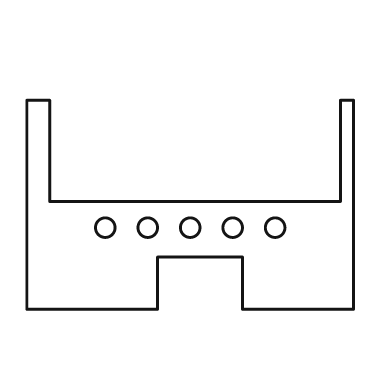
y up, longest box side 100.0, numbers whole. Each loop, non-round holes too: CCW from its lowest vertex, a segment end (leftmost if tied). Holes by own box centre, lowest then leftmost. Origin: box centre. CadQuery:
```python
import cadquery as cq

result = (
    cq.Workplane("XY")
    .moveTo(-50.0, -32.0)
    .lineTo(-10.0, -32.0)
    .lineTo(-10.0, -16.0)
    .lineTo(16.0, -16.0)
    .lineTo(16.0, -32.0)
    .lineTo(50.0, -32.0)
    .lineTo(50.0, 32.0)
    .lineTo(46.0, 32.0)
    .lineTo(46.0, 1.0)
    .lineTo(-43.0, 1.0)
    .lineTo(-43.0, 32.0)
    .lineTo(-50.0, 32.0)
    .close()
    .moveTo(-26.0, -7.0)
    .circle(3.0)
    .moveTo(-13.0, -7.0)
    .circle(3.0)
    .moveTo(0.0, -7.0)
    .circle(3.0)
    .moveTo(13.0, -7.0)
    .circle(3.0)
    .moveTo(26.0, -7.0)
    .circle(3.0)
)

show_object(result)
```